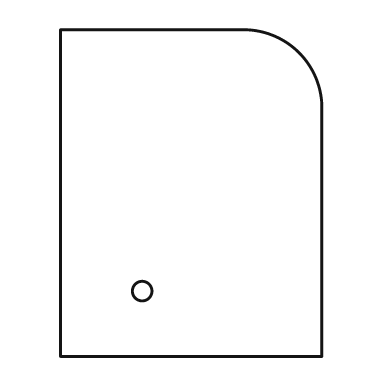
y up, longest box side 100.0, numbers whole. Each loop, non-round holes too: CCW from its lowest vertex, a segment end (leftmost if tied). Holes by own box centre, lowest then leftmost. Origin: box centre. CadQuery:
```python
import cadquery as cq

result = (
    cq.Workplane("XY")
    .moveTo(-40.0, -50.0)
    .lineTo(40.0, -50.0)
    .lineTo(40.0, 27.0)
    .threePointArc((33.0, 43.0), (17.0, 50.0))
    .lineTo(-40.0, 50.0)
    .close()
    .moveTo(-15.0, -30.0)
    .circle(3.0)
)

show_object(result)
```